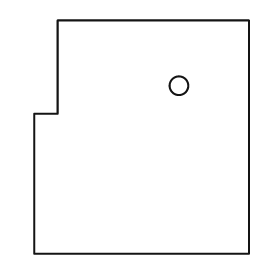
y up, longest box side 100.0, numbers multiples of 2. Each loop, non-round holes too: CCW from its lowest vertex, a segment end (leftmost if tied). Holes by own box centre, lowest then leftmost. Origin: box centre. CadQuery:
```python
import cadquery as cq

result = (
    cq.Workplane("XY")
    .moveTo(-46.0, -50.0)
    .lineTo(46.0, -50.0)
    .lineTo(46.0, 50.0)
    .lineTo(-36.0, 50.0)
    .lineTo(-36.0, 10.0)
    .lineTo(-46.0, 10.0)
    .close()
    .moveTo(16.0, 22.0)
    .circle(4.0)
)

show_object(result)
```